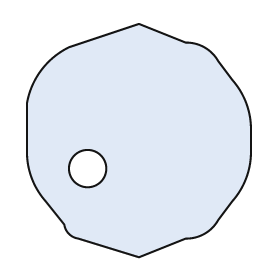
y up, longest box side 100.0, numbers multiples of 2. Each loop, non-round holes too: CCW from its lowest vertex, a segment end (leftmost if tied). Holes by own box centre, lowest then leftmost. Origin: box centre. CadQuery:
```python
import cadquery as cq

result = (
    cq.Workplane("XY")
    .moveTo(0.0, -50.0)
    .lineTo(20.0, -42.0)
    .threePointArc((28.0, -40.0), (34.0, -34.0))
    .lineTo(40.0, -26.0)
    .threePointArc((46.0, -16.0), (48.0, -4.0))
    .lineTo(48.0, 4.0)
    .threePointArc((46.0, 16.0), (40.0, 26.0))
    .lineTo(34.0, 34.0)
    .threePointArc((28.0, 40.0), (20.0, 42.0))
    .lineTo(0.0, 50.0)
    .lineTo(-30.0, 40.0)
    .threePointArc((-42.0, 30.0), (-48.0, 16.0))
    .lineTo(-48.0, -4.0)
    .threePointArc((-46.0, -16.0), (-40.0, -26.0))
    .lineTo(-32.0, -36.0)
    .threePointArc((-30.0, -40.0), (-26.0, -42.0))
    .close()
    .moveTo(-22.0, -12.0)
    .circle(8.0)
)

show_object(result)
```